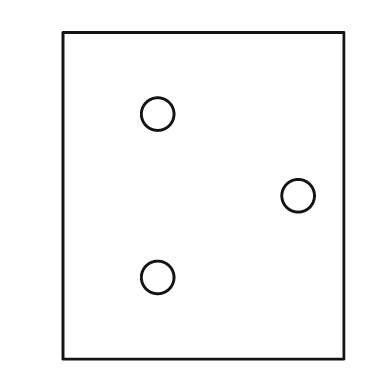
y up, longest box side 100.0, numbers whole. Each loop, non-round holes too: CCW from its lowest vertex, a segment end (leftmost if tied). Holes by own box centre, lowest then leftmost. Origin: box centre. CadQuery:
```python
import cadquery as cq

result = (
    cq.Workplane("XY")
    .moveTo(-43.0, -50.0)
    .lineTo(43.0, -50.0)
    .lineTo(43.0, 50.0)
    .lineTo(-43.0, 50.0)
    .close()
    .moveTo(-14.0, -25.0)
    .circle(5.0)
    .moveTo(29.0, 0.0)
    .circle(5.0)
    .moveTo(-14.0, 25.0)
    .circle(5.0)
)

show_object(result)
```